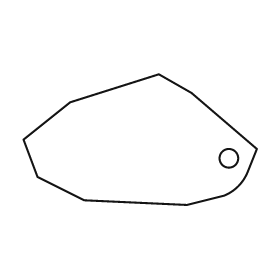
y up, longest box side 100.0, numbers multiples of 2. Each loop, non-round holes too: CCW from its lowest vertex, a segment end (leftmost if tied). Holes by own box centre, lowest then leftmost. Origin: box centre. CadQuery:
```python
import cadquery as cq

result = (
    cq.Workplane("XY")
    .moveTo(20.0, -28.0)
    .lineTo(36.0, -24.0)
    .threePointArc((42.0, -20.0), (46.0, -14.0))
    .lineTo(50.0, -4.0)
    .lineTo(22.0, 20.0)
    .lineTo(8.0, 28.0)
    .lineTo(-30.0, 16.0)
    .lineTo(-50.0, 0.0)
    .lineTo(-44.0, -16.0)
    .lineTo(-24.0, -26.0)
    .close()
    .moveTo(38.0, -8.0)
    .circle(4.0)
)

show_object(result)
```